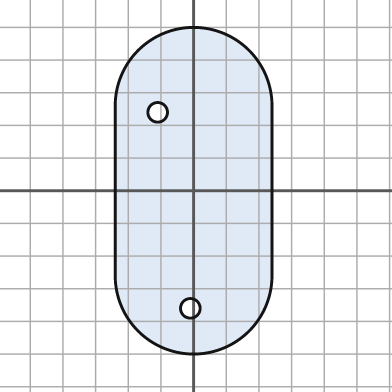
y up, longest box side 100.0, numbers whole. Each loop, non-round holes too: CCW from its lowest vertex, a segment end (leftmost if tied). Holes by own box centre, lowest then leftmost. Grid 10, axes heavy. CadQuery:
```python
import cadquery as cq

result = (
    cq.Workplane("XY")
    .moveTo(-24.0, -26.0)
    .threePointArc((0.0, -50.0), (24.0, -26.0))
    .lineTo(24.0, 26.0)
    .threePointArc((0.0, 50.0), (-24.0, 26.0))
    .close()
    .moveTo(-1.0, -36.0)
    .circle(3.0)
    .moveTo(-11.0, 24.0)
    .circle(3.0)
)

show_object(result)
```